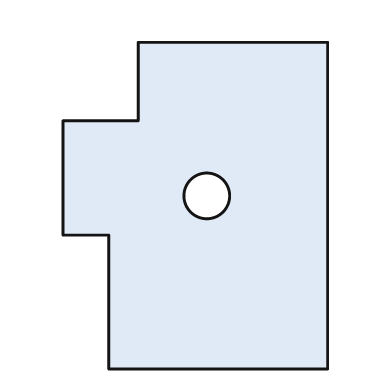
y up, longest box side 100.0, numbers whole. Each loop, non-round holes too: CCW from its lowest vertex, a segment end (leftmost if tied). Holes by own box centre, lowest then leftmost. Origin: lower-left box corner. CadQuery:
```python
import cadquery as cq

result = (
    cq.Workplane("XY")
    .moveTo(14.0, 0.0)
    .lineTo(81.0, 0.0)
    .lineTo(81.0, 100.0)
    .lineTo(23.0, 100.0)
    .lineTo(23.0, 76.0)
    .lineTo(0.0, 76.0)
    .lineTo(0.0, 41.0)
    .lineTo(14.0, 41.0)
    .close()
    .moveTo(44.0, 53.0)
    .circle(7.0)
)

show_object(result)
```